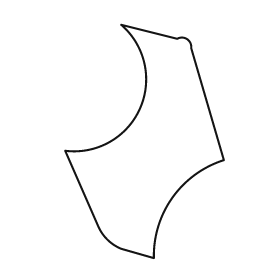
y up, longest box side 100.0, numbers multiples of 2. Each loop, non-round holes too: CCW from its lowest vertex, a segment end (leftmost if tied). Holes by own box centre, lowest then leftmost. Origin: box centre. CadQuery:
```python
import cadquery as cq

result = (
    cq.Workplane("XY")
    .moveTo(4.0, -50.0)
    .threePointArc((12.0, -24.0), (34.0, -8.0))
    .lineTo(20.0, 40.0)
    .threePointArc((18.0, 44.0), (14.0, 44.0))
    .lineTo(-10.0, 50.0)
    .threePointArc((-2.0, 14.0), (-34.0, -4.0))
    .lineTo(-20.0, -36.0)
    .threePointArc((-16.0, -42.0), (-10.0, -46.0))
    .close()
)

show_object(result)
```